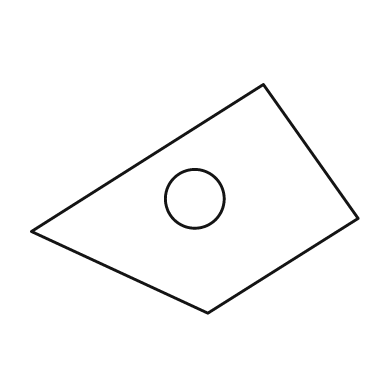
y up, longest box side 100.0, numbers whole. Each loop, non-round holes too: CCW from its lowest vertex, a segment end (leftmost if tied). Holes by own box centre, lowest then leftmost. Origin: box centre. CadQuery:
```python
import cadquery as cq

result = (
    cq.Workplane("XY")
    .moveTo(4.0, -35.0)
    .lineTo(50.0, -6.0)
    .lineTo(21.0, 35.0)
    .lineTo(-50.0, -10.0)
    .close()
    .moveTo(0.0, 0.0)
    .circle(9.0)
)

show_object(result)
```